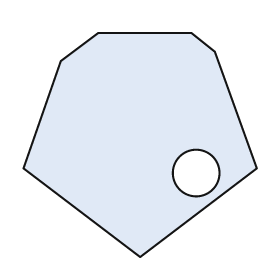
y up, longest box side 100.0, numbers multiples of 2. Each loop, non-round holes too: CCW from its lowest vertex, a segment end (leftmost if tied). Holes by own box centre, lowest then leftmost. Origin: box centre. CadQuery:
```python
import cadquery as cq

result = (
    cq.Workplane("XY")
    .moveTo(0.0, -48.0)
    .lineTo(50.0, -10.0)
    .lineTo(32.0, 40.0)
    .lineTo(22.0, 48.0)
    .lineTo(-18.0, 48.0)
    .lineTo(-34.0, 36.0)
    .lineTo(-50.0, -10.0)
    .close()
    .moveTo(24.0, -12.0)
    .circle(10.0)
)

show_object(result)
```